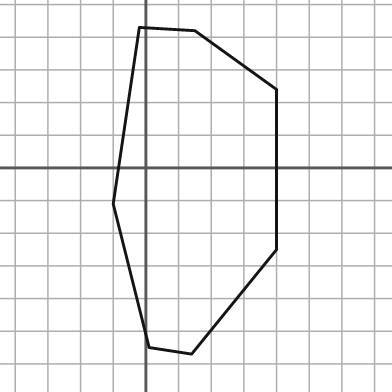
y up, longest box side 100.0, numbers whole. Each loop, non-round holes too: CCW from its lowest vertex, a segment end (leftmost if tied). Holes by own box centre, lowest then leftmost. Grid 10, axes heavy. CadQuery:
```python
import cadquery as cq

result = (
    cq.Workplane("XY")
    .moveTo(14.0, -57.0)
    .lineTo(40.0, -25.0)
    .lineTo(40.0, 24.0)
    .lineTo(15.0, 42.0)
    .lineTo(-2.0, 43.0)
    .lineTo(-10.0, -11.0)
    .lineTo(1.0, -55.0)
    .close()
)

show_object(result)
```